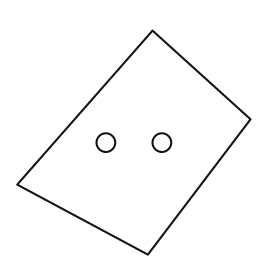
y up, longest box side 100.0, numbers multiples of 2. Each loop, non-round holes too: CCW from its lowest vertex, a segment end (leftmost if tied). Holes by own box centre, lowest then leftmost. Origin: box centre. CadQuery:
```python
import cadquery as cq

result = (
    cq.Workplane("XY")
    .moveTo(6.0, -48.0)
    .lineTo(50.0, 10.0)
    .lineTo(8.0, 48.0)
    .lineTo(-50.0, -18.0)
    .close()
    .moveTo(-12.0, 0.0)
    .circle(4.0)
    .moveTo(12.0, 0.0)
    .circle(4.0)
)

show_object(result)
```